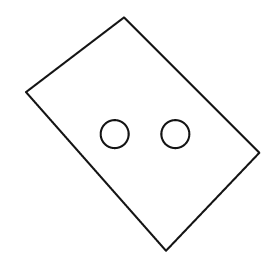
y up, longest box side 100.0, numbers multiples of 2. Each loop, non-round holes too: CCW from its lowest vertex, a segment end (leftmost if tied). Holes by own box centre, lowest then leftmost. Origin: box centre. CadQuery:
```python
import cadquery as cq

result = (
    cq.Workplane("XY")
    .moveTo(10.0, -50.0)
    .lineTo(50.0, -8.0)
    .lineTo(-8.0, 50.0)
    .lineTo(-50.0, 18.0)
    .close()
    .moveTo(-12.0, 0.0)
    .circle(6.0)
    .moveTo(14.0, 0.0)
    .circle(6.0)
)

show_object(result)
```